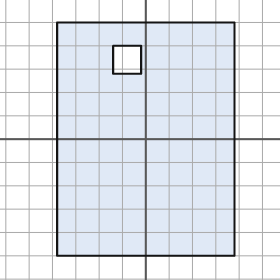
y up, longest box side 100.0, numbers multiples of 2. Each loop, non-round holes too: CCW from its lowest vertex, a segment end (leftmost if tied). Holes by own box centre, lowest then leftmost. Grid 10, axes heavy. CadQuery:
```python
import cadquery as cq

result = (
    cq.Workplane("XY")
    .moveTo(-38.0, -50.0)
    .lineTo(38.0, -50.0)
    .lineTo(38.0, 50.0)
    .lineTo(-38.0, 50.0)
    .close()
    .moveTo(-14.0, 28.0)
    .lineTo(-2.0, 28.0)
    .lineTo(-2.0, 40.0)
    .lineTo(-14.0, 40.0)
    .close()
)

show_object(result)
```